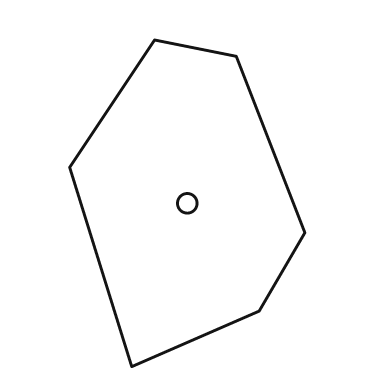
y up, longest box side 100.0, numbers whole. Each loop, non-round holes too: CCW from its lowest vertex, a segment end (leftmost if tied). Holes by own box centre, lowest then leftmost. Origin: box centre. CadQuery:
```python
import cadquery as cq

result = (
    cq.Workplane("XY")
    .moveTo(-17.0, -50.0)
    .lineTo(22.0, -33.0)
    .lineTo(36.0, -9.0)
    .lineTo(15.0, 45.0)
    .lineTo(-10.0, 50.0)
    .lineTo(-36.0, 11.0)
    .close()
    .moveTo(0.0, 0.0)
    .circle(3.0)
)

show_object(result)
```